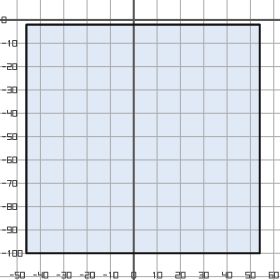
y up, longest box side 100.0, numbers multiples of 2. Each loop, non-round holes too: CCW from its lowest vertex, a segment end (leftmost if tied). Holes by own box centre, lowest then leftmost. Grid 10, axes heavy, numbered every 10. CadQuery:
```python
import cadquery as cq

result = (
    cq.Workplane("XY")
    .moveTo(-46.0, -100.0)
    .lineTo(54.0, -100.0)
    .lineTo(54.0, -2.0)
    .lineTo(-46.0, -2.0)
    .close()
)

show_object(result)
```